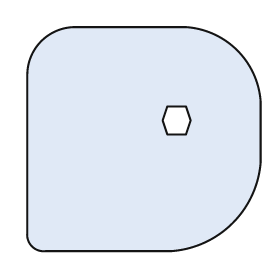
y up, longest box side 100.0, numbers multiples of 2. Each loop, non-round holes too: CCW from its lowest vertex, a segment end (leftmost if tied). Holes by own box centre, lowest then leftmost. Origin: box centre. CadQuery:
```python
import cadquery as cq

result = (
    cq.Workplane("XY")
    .moveTo(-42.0, -48.0)
    .lineTo(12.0, -48.0)
    .threePointArc((38.0, -36.0), (50.0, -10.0))
    .lineTo(50.0, 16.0)
    .threePointArc((40.0, 38.0), (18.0, 48.0))
    .lineTo(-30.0, 48.0)
    .threePointArc((-44.0, 42.0), (-50.0, 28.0))
    .lineTo(-50.0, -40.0)
    .threePointArc((-48.0, -46.0), (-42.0, -48.0))
    .close()
    .moveTo(10.0, 2.0)
    .lineTo(18.0, 2.0)
    .lineTo(20.0, 8.0)
    .lineTo(18.0, 14.0)
    .lineTo(10.0, 14.0)
    .lineTo(8.0, 8.0)
    .close()
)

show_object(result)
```